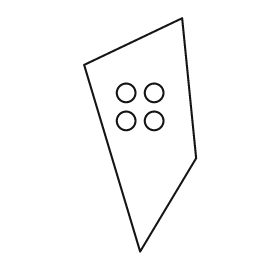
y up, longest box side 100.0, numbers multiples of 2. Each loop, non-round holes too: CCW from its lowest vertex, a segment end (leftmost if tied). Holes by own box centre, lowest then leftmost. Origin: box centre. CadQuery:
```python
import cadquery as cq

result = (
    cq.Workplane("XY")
    .moveTo(0.0, -50.0)
    .lineTo(24.0, -10.0)
    .lineTo(18.0, 50.0)
    .lineTo(-24.0, 30.0)
    .close()
    .moveTo(-6.0, 6.0)
    .circle(4.0)
    .moveTo(6.0, 6.0)
    .circle(4.0)
    .moveTo(-6.0, 18.0)
    .circle(4.0)
    .moveTo(6.0, 18.0)
    .circle(4.0)
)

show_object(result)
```